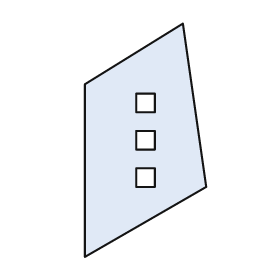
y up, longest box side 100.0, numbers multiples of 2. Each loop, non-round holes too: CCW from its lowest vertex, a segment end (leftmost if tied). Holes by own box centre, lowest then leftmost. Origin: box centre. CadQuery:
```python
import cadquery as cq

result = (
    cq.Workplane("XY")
    .moveTo(-26.0, -50.0)
    .lineTo(26.0, -20.0)
    .lineTo(16.0, 50.0)
    .lineTo(-26.0, 24.0)
    .close()
    .moveTo(-4.0, -20.0)
    .lineTo(4.0, -20.0)
    .lineTo(4.0, -12.0)
    .lineTo(-4.0, -12.0)
    .close()
    .moveTo(-4.0, -4.0)
    .lineTo(4.0, -4.0)
    .lineTo(4.0, 4.0)
    .lineTo(-4.0, 4.0)
    .close()
    .moveTo(-4.0, 12.0)
    .lineTo(4.0, 12.0)
    .lineTo(4.0, 20.0)
    .lineTo(-4.0, 20.0)
    .close()
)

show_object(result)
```